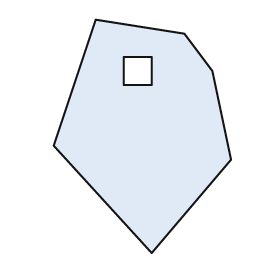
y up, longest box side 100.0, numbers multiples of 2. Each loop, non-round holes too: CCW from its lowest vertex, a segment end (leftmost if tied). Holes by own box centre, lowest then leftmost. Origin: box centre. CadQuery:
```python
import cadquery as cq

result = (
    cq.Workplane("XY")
    .moveTo(4.0, -50.0)
    .lineTo(38.0, -10.0)
    .lineTo(30.0, 28.0)
    .lineTo(18.0, 44.0)
    .lineTo(-20.0, 50.0)
    .lineTo(-38.0, -4.0)
    .close()
    .moveTo(-8.0, 22.0)
    .lineTo(4.0, 22.0)
    .lineTo(4.0, 34.0)
    .lineTo(-8.0, 34.0)
    .close()
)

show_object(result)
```